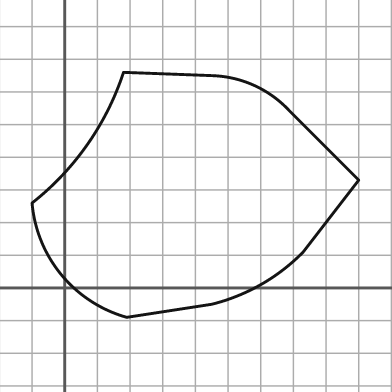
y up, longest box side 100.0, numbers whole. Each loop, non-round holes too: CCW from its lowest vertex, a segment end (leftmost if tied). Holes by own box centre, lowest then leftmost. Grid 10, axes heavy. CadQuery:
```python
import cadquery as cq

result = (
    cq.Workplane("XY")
    .moveTo(19.0, -9.0)
    .lineTo(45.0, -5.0)
    .threePointArc((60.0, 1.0), (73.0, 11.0))
    .lineTo(90.0, 33.0)
    .lineTo(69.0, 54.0)
    .threePointArc((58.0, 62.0), (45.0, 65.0))
    .lineTo(18.0, 66.0)
    .threePointArc((7.0, 44.0), (-10.0, 26.0))
    .threePointArc((-1.0, 4.0), (19.0, -9.0))
    .close()
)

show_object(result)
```